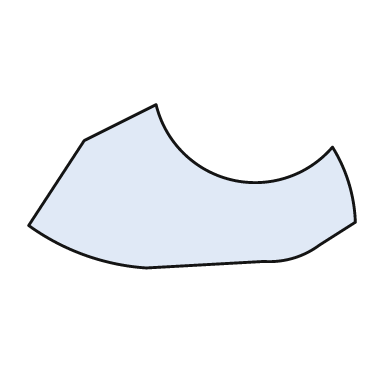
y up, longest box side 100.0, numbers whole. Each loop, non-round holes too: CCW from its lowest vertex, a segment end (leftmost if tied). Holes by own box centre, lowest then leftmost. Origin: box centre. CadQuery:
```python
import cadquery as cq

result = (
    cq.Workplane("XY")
    .moveTo(-14.0, -25.0)
    .lineTo(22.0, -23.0)
    .threePointArc((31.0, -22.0), (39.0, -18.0))
    .lineTo(50.0, -11.0)
    .threePointArc((48.0, 1.0), (43.0, 12.0))
    .threePointArc((12.0, 2.0), (-11.0, 25.0))
    .lineTo(-33.0, 14.0)
    .lineTo(-50.0, -12.0)
    .threePointArc((-33.0, -21.0), (-14.0, -25.0))
    .close()
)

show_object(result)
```